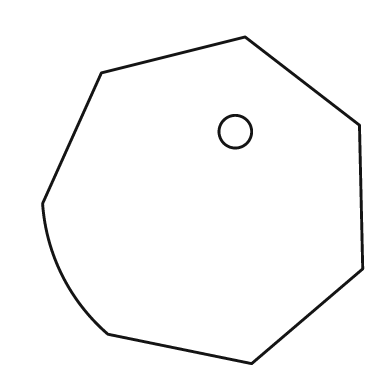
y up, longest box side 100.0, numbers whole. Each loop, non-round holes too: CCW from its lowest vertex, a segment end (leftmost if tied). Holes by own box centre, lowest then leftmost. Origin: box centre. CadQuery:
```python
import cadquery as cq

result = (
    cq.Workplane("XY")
    .moveTo(15.0, -50.0)
    .lineTo(49.0, -21.0)
    .lineTo(48.0, 23.0)
    .lineTo(13.0, 50.0)
    .lineTo(-31.0, 39.0)
    .lineTo(-49.0, -1.0)
    .threePointArc((-43.0, -23.0), (-29.0, -41.0))
    .close()
    .moveTo(10.0, 21.0)
    .circle(5.0)
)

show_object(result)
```